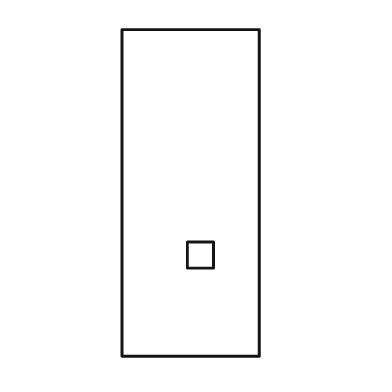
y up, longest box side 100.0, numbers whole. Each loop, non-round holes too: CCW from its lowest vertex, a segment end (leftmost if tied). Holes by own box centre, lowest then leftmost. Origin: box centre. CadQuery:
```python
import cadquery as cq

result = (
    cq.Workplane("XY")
    .moveTo(-21.0, -50.0)
    .lineTo(21.0, -50.0)
    .lineTo(21.0, 50.0)
    .lineTo(-21.0, 50.0)
    .close()
    .moveTo(-1.0, -23.0)
    .lineTo(7.0, -23.0)
    .lineTo(7.0, -15.0)
    .lineTo(-1.0, -15.0)
    .close()
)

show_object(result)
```